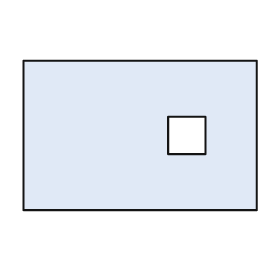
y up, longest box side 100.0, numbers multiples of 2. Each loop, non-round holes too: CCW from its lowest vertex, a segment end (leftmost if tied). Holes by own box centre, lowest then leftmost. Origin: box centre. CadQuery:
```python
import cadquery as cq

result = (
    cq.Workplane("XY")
    .moveTo(-50.0, -32.0)
    .lineTo(50.0, -32.0)
    .lineTo(50.0, 32.0)
    .lineTo(-50.0, 32.0)
    .close()
    .moveTo(12.0, -8.0)
    .lineTo(28.0, -8.0)
    .lineTo(28.0, 8.0)
    .lineTo(12.0, 8.0)
    .close()
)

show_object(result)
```